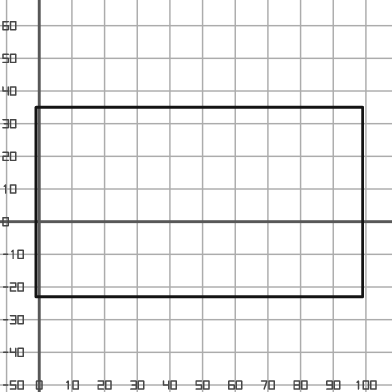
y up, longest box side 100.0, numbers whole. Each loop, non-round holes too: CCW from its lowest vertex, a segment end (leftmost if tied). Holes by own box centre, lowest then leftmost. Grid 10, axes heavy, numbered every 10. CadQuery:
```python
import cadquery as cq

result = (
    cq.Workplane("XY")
    .moveTo(-1.0, -23.0)
    .lineTo(99.0, -23.0)
    .lineTo(99.0, 35.0)
    .lineTo(-1.0, 35.0)
    .close()
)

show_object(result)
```